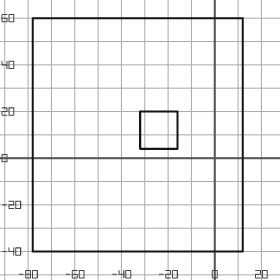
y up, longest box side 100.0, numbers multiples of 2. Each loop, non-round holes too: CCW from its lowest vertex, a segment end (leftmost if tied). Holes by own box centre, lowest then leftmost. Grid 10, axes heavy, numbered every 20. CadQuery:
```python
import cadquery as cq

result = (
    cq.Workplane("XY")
    .moveTo(-78.0, -40.0)
    .lineTo(12.0, -40.0)
    .lineTo(12.0, 60.0)
    .lineTo(-78.0, 60.0)
    .close()
    .moveTo(-32.0, 4.0)
    .lineTo(-16.0, 4.0)
    .lineTo(-16.0, 20.0)
    .lineTo(-32.0, 20.0)
    .close()
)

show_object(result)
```